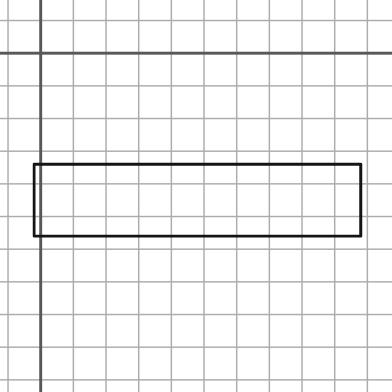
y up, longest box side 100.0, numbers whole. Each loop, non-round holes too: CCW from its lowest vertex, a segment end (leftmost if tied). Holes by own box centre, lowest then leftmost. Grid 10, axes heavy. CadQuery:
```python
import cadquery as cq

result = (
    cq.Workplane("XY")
    .moveTo(-2.0, -56.0)
    .lineTo(98.0, -56.0)
    .lineTo(98.0, -34.0)
    .lineTo(-2.0, -34.0)
    .close()
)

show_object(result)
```